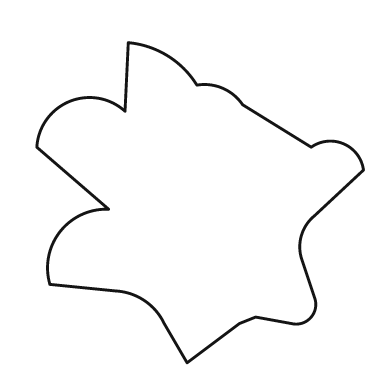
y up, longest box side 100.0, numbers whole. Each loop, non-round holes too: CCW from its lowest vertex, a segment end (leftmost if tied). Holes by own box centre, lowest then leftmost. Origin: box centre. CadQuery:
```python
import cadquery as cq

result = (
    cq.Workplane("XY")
    .moveTo(-4.0, -49.0)
    .lineTo(12.0, -37.0)
    .lineTo(17.0, -35.0)
    .lineTo(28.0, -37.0)
    .threePointArc((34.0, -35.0), (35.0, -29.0))
    .lineTo(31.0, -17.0)
    .threePointArc((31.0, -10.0), (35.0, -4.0))
    .lineTo(50.0, 10.0)
    .threePointArc((44.0, 18.0), (34.0, 17.0))
    .lineTo(13.0, 30.0)
    .threePointArc((7.0, 35.0), (-1.0, 36.0))
    .threePointArc((-10.0, 45.0), (-22.0, 49.0))
    .lineTo(-23.0, 28.0)
    .threePointArc((-40.0, 31.0), (-50.0, 17.0))
    .lineTo(-28.0, -2.0)
    .threePointArc((-43.0, -9.0), (-46.0, -25.0))
    .lineTo(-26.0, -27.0)
    .threePointArc((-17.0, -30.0), (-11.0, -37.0))
    .close()
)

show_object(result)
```